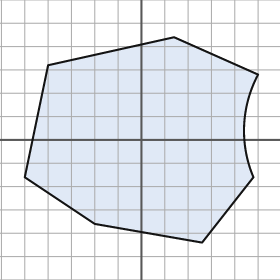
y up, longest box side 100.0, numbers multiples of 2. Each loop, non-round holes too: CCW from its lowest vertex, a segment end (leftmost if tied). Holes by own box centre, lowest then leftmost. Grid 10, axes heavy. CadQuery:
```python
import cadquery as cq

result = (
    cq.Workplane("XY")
    .moveTo(26.0, -44.0)
    .lineTo(48.0, -16.0)
    .threePointArc((44.0, 6.0), (50.0, 28.0))
    .lineTo(14.0, 44.0)
    .lineTo(-40.0, 32.0)
    .lineTo(-50.0, -16.0)
    .lineTo(-20.0, -36.0)
    .close()
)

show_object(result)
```